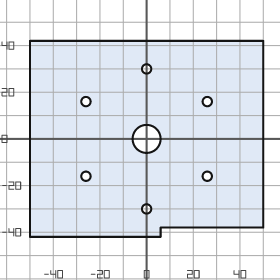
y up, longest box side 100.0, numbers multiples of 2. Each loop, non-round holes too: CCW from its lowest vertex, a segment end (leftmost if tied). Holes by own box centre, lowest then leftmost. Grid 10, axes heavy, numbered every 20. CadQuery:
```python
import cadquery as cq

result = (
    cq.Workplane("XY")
    .moveTo(-50.0, -42.0)
    .lineTo(6.0, -42.0)
    .lineTo(6.0, -38.0)
    .lineTo(50.0, -38.0)
    .lineTo(50.0, 42.0)
    .lineTo(-50.0, 42.0)
    .close()
    .moveTo(0.0, -30.0)
    .circle(2.0)
    .moveTo(-26.0, -16.0)
    .circle(2.0)
    .moveTo(26.0, -16.0)
    .circle(2.0)
    .moveTo(0.0, 0.0)
    .circle(6.0)
    .moveTo(-26.0, 16.0)
    .circle(2.0)
    .moveTo(26.0, 16.0)
    .circle(2.0)
    .moveTo(0.0, 30.0)
    .circle(2.0)
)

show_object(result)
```